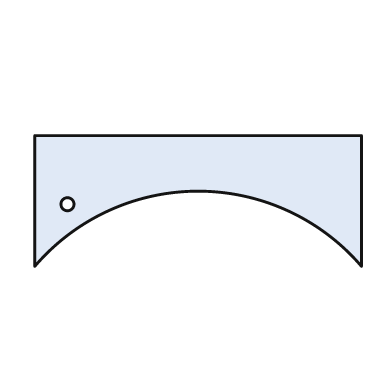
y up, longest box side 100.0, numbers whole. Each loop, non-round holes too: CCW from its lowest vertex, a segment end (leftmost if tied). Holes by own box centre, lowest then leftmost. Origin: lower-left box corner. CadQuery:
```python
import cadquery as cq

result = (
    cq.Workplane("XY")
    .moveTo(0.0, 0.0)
    .threePointArc((50.0, 23.0), (100.0, 0.0))
    .lineTo(100.0, 40.0)
    .lineTo(0.0, 40.0)
    .close()
    .moveTo(10.0, 19.0)
    .circle(2.0)
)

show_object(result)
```